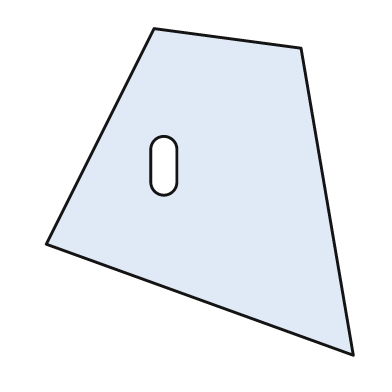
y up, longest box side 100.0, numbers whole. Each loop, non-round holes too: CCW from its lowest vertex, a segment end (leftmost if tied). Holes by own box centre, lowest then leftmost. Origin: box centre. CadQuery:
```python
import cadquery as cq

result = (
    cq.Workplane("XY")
    .moveTo(47.0, -50.0)
    .lineTo(31.0, 44.0)
    .lineTo(-14.0, 50.0)
    .lineTo(-47.0, -16.0)
    .close()
    .moveTo(-15.0, 3.0)
    .threePointArc((-11.0, -1.0), (-7.0, 3.0))
    .lineTo(-7.0, 13.0)
    .threePointArc((-11.0, 17.0), (-15.0, 13.0))
    .close()
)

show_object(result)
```